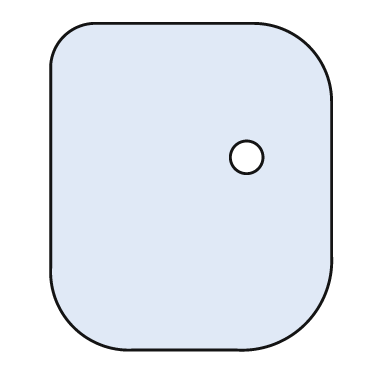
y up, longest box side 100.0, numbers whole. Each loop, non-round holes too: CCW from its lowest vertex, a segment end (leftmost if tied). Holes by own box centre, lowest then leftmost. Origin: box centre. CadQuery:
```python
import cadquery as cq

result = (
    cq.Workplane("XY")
    .moveTo(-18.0, -50.0)
    .lineTo(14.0, -50.0)
    .threePointArc((35.0, -42.0), (43.0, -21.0))
    .lineTo(43.0, 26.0)
    .threePointArc((36.0, 43.0), (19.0, 50.0))
    .lineTo(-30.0, 50.0)
    .threePointArc((-39.0, 46.0), (-43.0, 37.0))
    .lineTo(-43.0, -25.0)
    .threePointArc((-36.0, -43.0), (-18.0, -50.0))
    .close()
    .moveTo(17.0, 9.0)
    .circle(5.0)
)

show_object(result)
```